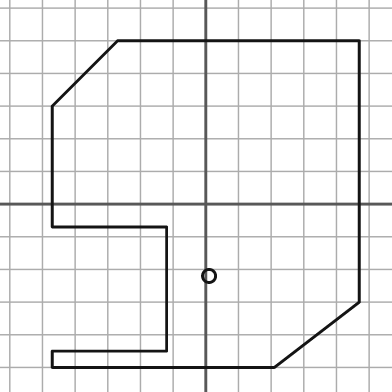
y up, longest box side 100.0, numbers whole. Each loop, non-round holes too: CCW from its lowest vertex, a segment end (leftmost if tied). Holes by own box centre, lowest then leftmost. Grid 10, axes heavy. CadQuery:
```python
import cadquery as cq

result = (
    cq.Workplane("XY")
    .moveTo(-47.0, -50.0)
    .lineTo(21.0, -50.0)
    .lineTo(47.0, -30.0)
    .lineTo(47.0, 50.0)
    .lineTo(-27.0, 50.0)
    .lineTo(-47.0, 30.0)
    .lineTo(-47.0, -7.0)
    .lineTo(-12.0, -7.0)
    .lineTo(-12.0, -45.0)
    .lineTo(-47.0, -45.0)
    .close()
    .moveTo(1.0, -22.0)
    .circle(2.0)
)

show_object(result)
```